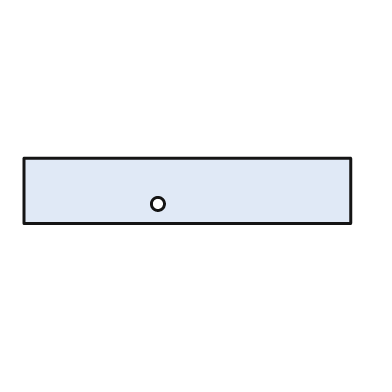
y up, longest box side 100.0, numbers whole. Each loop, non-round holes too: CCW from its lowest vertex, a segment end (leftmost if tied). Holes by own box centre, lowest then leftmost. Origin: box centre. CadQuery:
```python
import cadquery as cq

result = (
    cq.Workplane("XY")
    .moveTo(-50.0, -10.0)
    .lineTo(50.0, -10.0)
    .lineTo(50.0, 10.0)
    .lineTo(-50.0, 10.0)
    .close()
    .moveTo(-9.0, -4.0)
    .circle(2.0)
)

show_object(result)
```